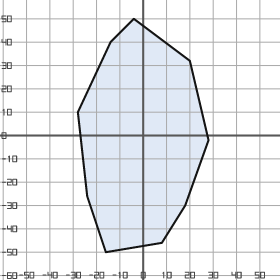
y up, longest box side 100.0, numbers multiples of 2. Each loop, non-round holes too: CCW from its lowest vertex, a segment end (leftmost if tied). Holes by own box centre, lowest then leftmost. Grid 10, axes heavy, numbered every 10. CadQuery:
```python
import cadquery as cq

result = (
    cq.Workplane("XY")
    .moveTo(-16.0, -50.0)
    .lineTo(8.0, -46.0)
    .lineTo(18.0, -30.0)
    .lineTo(28.0, -2.0)
    .lineTo(20.0, 32.0)
    .lineTo(-4.0, 50.0)
    .lineTo(-14.0, 40.0)
    .lineTo(-28.0, 10.0)
    .lineTo(-24.0, -26.0)
    .close()
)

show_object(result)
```